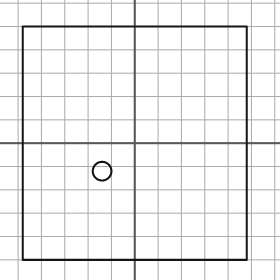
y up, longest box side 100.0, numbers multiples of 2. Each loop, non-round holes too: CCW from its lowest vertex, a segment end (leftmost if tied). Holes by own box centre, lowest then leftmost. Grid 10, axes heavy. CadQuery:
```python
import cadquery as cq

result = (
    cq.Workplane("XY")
    .moveTo(-48.0, -50.0)
    .lineTo(48.0, -50.0)
    .lineTo(48.0, 50.0)
    .lineTo(-48.0, 50.0)
    .close()
    .moveTo(-14.0, -12.0)
    .circle(4.0)
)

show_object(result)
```